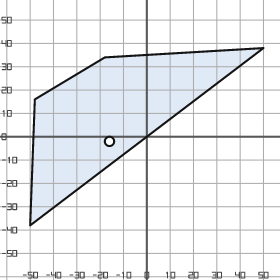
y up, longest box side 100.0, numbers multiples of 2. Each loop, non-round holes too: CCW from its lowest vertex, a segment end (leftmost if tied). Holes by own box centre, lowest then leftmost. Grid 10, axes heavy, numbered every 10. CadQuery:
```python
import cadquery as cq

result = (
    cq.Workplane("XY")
    .moveTo(-50.0, -38.0)
    .lineTo(50.0, 38.0)
    .lineTo(-18.0, 34.0)
    .lineTo(-48.0, 16.0)
    .close()
    .moveTo(-16.0, -2.0)
    .circle(2.0)
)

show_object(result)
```